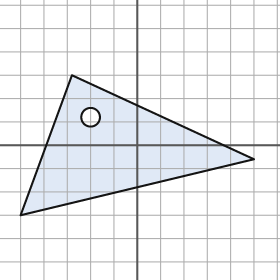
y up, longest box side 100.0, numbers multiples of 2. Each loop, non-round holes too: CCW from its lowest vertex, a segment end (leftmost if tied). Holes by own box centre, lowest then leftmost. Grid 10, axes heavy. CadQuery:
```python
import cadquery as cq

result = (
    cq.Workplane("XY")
    .moveTo(-50.0, -30.0)
    .lineTo(50.0, -6.0)
    .lineTo(-28.0, 30.0)
    .close()
    .moveTo(-20.0, 12.0)
    .circle(4.0)
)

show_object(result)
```